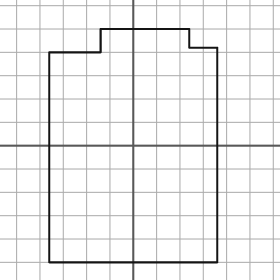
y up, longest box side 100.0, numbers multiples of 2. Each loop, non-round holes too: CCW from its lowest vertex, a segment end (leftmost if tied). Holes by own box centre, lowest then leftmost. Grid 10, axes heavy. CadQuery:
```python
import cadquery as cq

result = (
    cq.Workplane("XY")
    .moveTo(-36.0, -50.0)
    .lineTo(36.0, -50.0)
    .lineTo(36.0, 42.0)
    .lineTo(24.0, 42.0)
    .lineTo(24.0, 50.0)
    .lineTo(-14.0, 50.0)
    .lineTo(-14.0, 40.0)
    .lineTo(-36.0, 40.0)
    .close()
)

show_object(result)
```